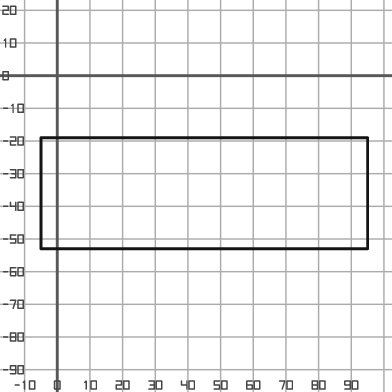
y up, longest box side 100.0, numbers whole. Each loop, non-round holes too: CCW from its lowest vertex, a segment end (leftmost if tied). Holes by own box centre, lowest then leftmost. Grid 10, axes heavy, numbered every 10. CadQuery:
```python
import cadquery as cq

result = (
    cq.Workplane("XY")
    .moveTo(-5.0, -53.0)
    .lineTo(95.0, -53.0)
    .lineTo(95.0, -19.0)
    .lineTo(-5.0, -19.0)
    .close()
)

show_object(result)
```